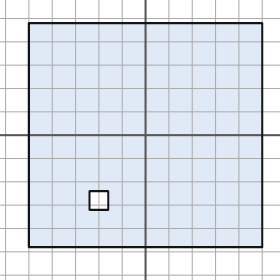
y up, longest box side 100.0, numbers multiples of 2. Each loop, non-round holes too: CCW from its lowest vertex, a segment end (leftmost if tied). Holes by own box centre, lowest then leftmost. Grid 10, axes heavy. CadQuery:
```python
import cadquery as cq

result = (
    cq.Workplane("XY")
    .moveTo(-50.0, -48.0)
    .lineTo(50.0, -48.0)
    .lineTo(50.0, 48.0)
    .lineTo(-50.0, 48.0)
    .close()
    .moveTo(-24.0, -32.0)
    .lineTo(-16.0, -32.0)
    .lineTo(-16.0, -24.0)
    .lineTo(-24.0, -24.0)
    .close()
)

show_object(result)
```